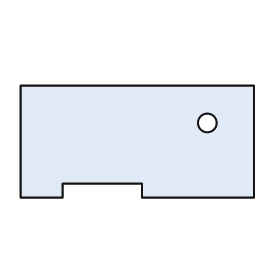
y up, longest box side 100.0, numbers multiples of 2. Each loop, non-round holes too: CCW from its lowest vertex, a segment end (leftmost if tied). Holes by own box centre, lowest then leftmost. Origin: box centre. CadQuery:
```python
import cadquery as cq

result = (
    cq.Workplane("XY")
    .moveTo(-50.0, -24.0)
    .lineTo(-32.0, -24.0)
    .lineTo(-32.0, -18.0)
    .lineTo(2.0, -18.0)
    .lineTo(2.0, -24.0)
    .lineTo(50.0, -24.0)
    .lineTo(50.0, 24.0)
    .lineTo(-50.0, 24.0)
    .close()
    .moveTo(30.0, 8.0)
    .circle(4.0)
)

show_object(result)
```